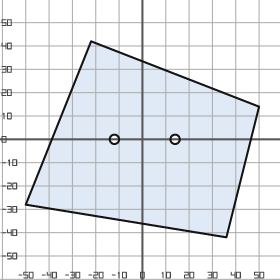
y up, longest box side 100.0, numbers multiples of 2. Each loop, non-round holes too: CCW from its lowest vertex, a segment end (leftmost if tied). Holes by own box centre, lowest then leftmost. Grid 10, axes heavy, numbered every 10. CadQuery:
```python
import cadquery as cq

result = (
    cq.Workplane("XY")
    .moveTo(36.0, -42.0)
    .lineTo(50.0, 14.0)
    .lineTo(-22.0, 42.0)
    .lineTo(-50.0, -28.0)
    .close()
    .moveTo(-12.0, 0.0)
    .circle(2.0)
    .moveTo(14.0, 0.0)
    .circle(2.0)
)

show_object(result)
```